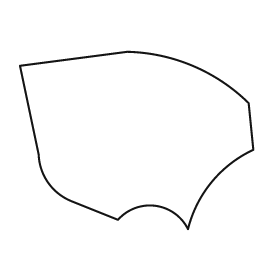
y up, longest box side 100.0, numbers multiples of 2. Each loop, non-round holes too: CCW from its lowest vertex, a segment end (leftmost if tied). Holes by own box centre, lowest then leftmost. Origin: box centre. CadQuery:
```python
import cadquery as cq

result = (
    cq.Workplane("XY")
    .moveTo(22.0, -38.0)
    .threePointArc((32.0, -18.0), (50.0, -4.0))
    .lineTo(48.0, 16.0)
    .threePointArc((24.0, 32.0), (-4.0, 38.0))
    .lineTo(-50.0, 32.0)
    .lineTo(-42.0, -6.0)
    .threePointArc((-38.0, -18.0), (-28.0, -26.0))
    .lineTo(-8.0, -34.0)
    .threePointArc((8.0, -28.0), (22.0, -38.0))
    .close()
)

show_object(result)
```